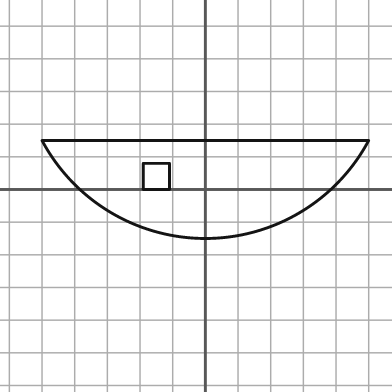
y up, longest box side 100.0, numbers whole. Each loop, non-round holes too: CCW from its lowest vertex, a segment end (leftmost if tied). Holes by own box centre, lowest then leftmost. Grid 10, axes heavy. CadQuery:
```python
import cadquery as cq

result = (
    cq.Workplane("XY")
    .moveTo(-50.0, 15.0)
    .threePointArc((0.0, -15.0), (50.0, 15.0))
    .close()
    .moveTo(-19.0, 0.0)
    .lineTo(-11.0, 0.0)
    .lineTo(-11.0, 8.0)
    .lineTo(-19.0, 8.0)
    .close()
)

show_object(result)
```